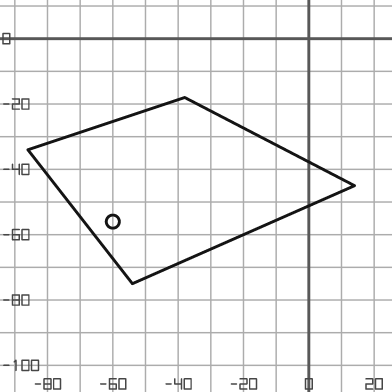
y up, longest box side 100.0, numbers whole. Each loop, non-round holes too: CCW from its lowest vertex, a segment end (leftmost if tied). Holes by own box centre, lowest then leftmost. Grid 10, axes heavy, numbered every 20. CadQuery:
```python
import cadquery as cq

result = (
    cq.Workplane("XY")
    .moveTo(-54.0, -75.0)
    .lineTo(14.0, -45.0)
    .lineTo(-38.0, -18.0)
    .lineTo(-86.0, -34.0)
    .close()
    .moveTo(-60.0, -56.0)
    .circle(2.0)
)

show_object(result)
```